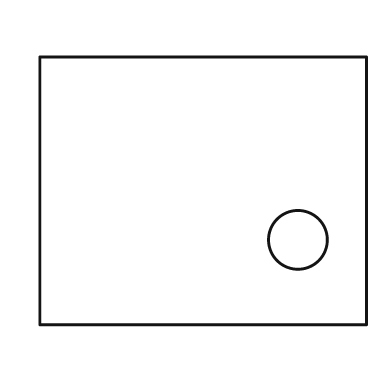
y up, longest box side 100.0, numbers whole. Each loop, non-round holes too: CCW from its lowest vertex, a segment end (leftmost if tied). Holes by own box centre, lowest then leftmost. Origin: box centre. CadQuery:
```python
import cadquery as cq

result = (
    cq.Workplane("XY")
    .moveTo(-50.0, -41.0)
    .lineTo(50.0, -41.0)
    .lineTo(50.0, 41.0)
    .lineTo(-50.0, 41.0)
    .close()
    .moveTo(29.0, -15.0)
    .circle(9.0)
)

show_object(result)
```